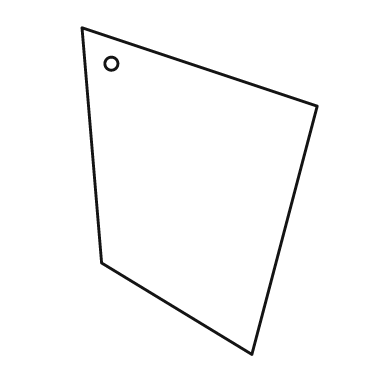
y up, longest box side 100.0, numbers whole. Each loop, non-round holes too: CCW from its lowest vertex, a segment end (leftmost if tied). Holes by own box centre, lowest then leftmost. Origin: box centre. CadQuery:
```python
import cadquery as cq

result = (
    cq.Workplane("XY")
    .moveTo(16.0, -50.0)
    .lineTo(36.0, 26.0)
    .lineTo(-36.0, 50.0)
    .lineTo(-30.0, -22.0)
    .close()
    .moveTo(-27.0, 39.0)
    .circle(2.0)
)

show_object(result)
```